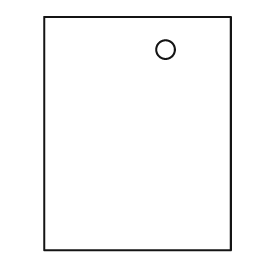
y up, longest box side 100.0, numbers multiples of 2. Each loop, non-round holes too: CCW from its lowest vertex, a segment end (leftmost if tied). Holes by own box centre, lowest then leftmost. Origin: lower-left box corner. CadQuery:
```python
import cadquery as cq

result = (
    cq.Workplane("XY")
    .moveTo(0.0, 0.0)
    .lineTo(80.0, 0.0)
    .lineTo(80.0, 100.0)
    .lineTo(0.0, 100.0)
    .close()
    .moveTo(52.0, 86.0)
    .circle(4.0)
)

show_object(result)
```